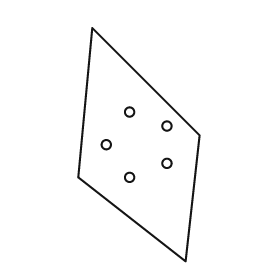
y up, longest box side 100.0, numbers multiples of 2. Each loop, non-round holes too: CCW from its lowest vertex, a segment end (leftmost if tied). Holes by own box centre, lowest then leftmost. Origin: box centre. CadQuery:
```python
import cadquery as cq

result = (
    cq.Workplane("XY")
    .moveTo(20.0, -50.0)
    .lineTo(26.0, 4.0)
    .lineTo(-20.0, 50.0)
    .lineTo(-26.0, -14.0)
    .close()
    .moveTo(-4.0, -14.0)
    .circle(2.0)
    .moveTo(12.0, -8.0)
    .circle(2.0)
    .moveTo(-14.0, 0.0)
    .circle(2.0)
    .moveTo(12.0, 8.0)
    .circle(2.0)
    .moveTo(-4.0, 14.0)
    .circle(2.0)
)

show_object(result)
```